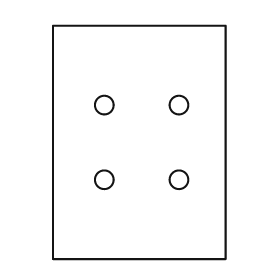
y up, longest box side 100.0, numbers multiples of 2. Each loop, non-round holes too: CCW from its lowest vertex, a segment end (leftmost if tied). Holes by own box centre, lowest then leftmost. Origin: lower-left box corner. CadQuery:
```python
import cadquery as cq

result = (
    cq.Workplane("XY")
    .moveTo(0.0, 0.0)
    .lineTo(74.0, 0.0)
    .lineTo(74.0, 100.0)
    .lineTo(0.0, 100.0)
    .close()
    .moveTo(22.0, 34.0)
    .circle(4.0)
    .moveTo(54.0, 34.0)
    .circle(4.0)
    .moveTo(22.0, 66.0)
    .circle(4.0)
    .moveTo(54.0, 66.0)
    .circle(4.0)
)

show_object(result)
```